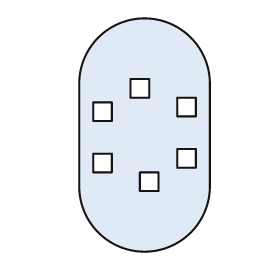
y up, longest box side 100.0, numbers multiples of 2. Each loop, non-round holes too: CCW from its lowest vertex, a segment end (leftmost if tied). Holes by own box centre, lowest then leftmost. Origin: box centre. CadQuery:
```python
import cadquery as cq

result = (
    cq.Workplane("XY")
    .moveTo(-28.0, -22.0)
    .threePointArc((0.0, -50.0), (28.0, -22.0))
    .lineTo(28.0, 22.0)
    .threePointArc((0.0, 50.0), (-28.0, 22.0))
    .close()
    .moveTo(-2.0, -24.0)
    .lineTo(6.0, -24.0)
    .lineTo(6.0, -16.0)
    .lineTo(-2.0, -16.0)
    .close()
    .moveTo(-22.0, -16.0)
    .lineTo(-14.0, -16.0)
    .lineTo(-14.0, -8.0)
    .lineTo(-22.0, -8.0)
    .close()
    .moveTo(14.0, -14.0)
    .lineTo(22.0, -14.0)
    .lineTo(22.0, -6.0)
    .lineTo(14.0, -6.0)
    .close()
    .moveTo(-22.0, 6.0)
    .lineTo(-14.0, 6.0)
    .lineTo(-14.0, 14.0)
    .lineTo(-22.0, 14.0)
    .close()
    .moveTo(14.0, 8.0)
    .lineTo(22.0, 8.0)
    .lineTo(22.0, 16.0)
    .lineTo(14.0, 16.0)
    .close()
    .moveTo(-6.0, 16.0)
    .lineTo(2.0, 16.0)
    .lineTo(2.0, 24.0)
    .lineTo(-6.0, 24.0)
    .close()
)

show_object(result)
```